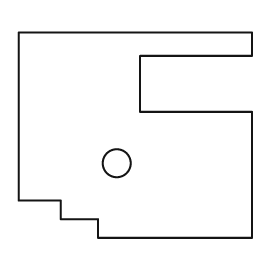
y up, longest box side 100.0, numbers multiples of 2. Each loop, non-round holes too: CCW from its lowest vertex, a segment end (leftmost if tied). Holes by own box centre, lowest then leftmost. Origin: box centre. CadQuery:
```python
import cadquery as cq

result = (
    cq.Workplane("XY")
    .moveTo(-16.0, -44.0)
    .lineTo(50.0, -44.0)
    .lineTo(50.0, 10.0)
    .lineTo(2.0, 10.0)
    .lineTo(2.0, 34.0)
    .lineTo(50.0, 34.0)
    .lineTo(50.0, 44.0)
    .lineTo(-50.0, 44.0)
    .lineTo(-50.0, -28.0)
    .lineTo(-32.0, -28.0)
    .lineTo(-32.0, -36.0)
    .lineTo(-16.0, -36.0)
    .close()
    .moveTo(-8.0, -12.0)
    .circle(6.0)
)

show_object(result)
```